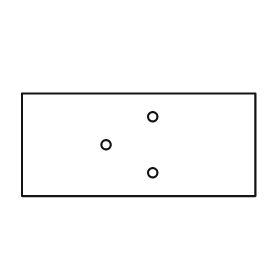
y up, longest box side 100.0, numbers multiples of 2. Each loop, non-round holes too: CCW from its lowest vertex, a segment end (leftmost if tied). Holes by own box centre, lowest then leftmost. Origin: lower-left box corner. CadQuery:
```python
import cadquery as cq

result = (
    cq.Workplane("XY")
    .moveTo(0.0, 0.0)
    .lineTo(100.0, 0.0)
    .lineTo(100.0, 44.0)
    .lineTo(0.0, 44.0)
    .close()
    .moveTo(56.0, 10.0)
    .circle(2.0)
    .moveTo(36.0, 22.0)
    .circle(2.0)
    .moveTo(56.0, 34.0)
    .circle(2.0)
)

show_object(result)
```